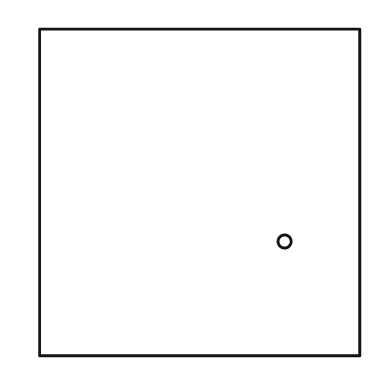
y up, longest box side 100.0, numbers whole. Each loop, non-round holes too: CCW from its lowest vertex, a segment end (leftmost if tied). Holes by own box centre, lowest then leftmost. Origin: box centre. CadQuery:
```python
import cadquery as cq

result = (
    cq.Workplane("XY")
    .moveTo(-49.0, -50.0)
    .lineTo(49.0, -50.0)
    .lineTo(49.0, 50.0)
    .lineTo(-49.0, 50.0)
    .close()
    .moveTo(26.0, -15.0)
    .circle(2.0)
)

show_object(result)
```